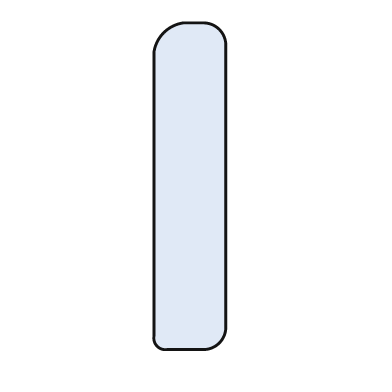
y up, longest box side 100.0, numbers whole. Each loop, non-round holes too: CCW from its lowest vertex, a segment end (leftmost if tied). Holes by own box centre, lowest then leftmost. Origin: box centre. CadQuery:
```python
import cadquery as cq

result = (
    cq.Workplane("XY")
    .moveTo(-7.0, -50.0)
    .lineTo(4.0, -50.0)
    .threePointArc((9.0, -48.0), (11.0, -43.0))
    .lineTo(11.0, 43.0)
    .threePointArc((9.0, 48.0), (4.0, 50.0))
    .lineTo(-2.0, 50.0)
    .threePointArc((-8.0, 47.0), (-11.0, 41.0))
    .lineTo(-11.0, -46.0)
    .threePointArc((-10.0, -49.0), (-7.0, -50.0))
    .close()
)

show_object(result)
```